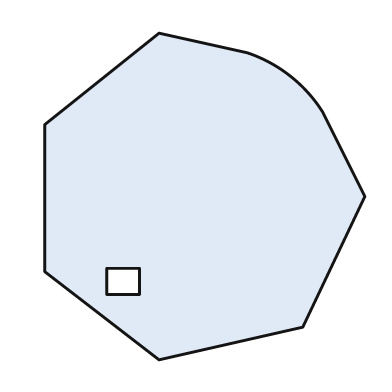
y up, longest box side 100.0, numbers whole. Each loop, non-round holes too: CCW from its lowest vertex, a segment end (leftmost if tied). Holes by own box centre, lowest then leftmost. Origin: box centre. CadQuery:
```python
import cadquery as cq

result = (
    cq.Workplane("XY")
    .moveTo(-14.0, -50.0)
    .lineTo(30.0, -40.0)
    .lineTo(49.0, 0.0)
    .lineTo(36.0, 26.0)
    .threePointArc((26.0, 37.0), (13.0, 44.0))
    .lineTo(-14.0, 50.0)
    .lineTo(-49.0, 22.0)
    .lineTo(-49.0, -23.0)
    .close()
    .moveTo(-30.0, -30.0)
    .lineTo(-20.0, -30.0)
    .lineTo(-20.0, -22.0)
    .lineTo(-30.0, -22.0)
    .close()
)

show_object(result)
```